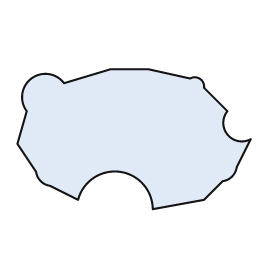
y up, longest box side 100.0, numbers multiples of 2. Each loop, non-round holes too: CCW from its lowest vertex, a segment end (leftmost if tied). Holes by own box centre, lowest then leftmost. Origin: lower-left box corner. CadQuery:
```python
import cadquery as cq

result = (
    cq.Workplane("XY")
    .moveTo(58.0, 0.0)
    .lineTo(80.0, 4.0)
    .lineTo(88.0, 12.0)
    .threePointArc((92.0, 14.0), (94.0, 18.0))
    .lineTo(100.0, 30.0)
    .threePointArc((90.0, 32.0), (90.0, 42.0))
    .lineTo(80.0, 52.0)
    .threePointArc((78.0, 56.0), (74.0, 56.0))
    .lineTo(56.0, 60.0)
    .lineTo(40.0, 60.0)
    .lineTo(20.0, 54.0)
    .threePointArc((6.0, 56.0), (4.0, 42.0))
    .lineTo(0.0, 28.0)
    .lineTo(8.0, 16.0)
    .threePointArc((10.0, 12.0), (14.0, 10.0))
    .lineTo(26.0, 4.0)
    .threePointArc((44.0, 16.0), (58.0, 0.0))
    .close()
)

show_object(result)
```